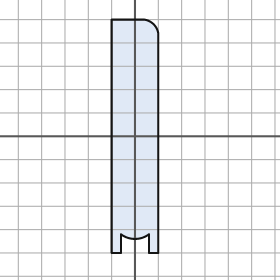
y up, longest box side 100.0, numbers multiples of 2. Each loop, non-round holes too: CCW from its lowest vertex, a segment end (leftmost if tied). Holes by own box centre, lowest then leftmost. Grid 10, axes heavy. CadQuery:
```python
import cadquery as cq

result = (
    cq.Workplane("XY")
    .moveTo(-10.0, -50.0)
    .lineTo(-6.0, -50.0)
    .lineTo(-6.0, -42.0)
    .threePointArc((0.0, -44.0), (6.0, -42.0))
    .lineTo(6.0, -50.0)
    .lineTo(10.0, -50.0)
    .lineTo(10.0, 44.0)
    .threePointArc((8.0, 48.0), (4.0, 50.0))
    .lineTo(-10.0, 50.0)
    .close()
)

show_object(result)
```